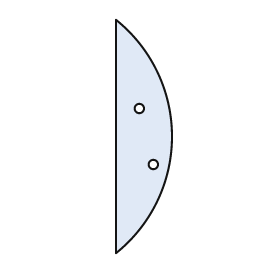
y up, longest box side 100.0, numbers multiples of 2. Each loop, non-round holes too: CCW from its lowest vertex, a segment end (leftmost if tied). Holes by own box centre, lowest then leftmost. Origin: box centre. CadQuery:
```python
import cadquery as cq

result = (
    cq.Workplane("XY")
    .moveTo(-12.0, -50.0)
    .threePointArc((12.0, 0.0), (-12.0, 50.0))
    .close()
    .moveTo(4.0, -12.0)
    .circle(2.0)
    .moveTo(-2.0, 12.0)
    .circle(2.0)
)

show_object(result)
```